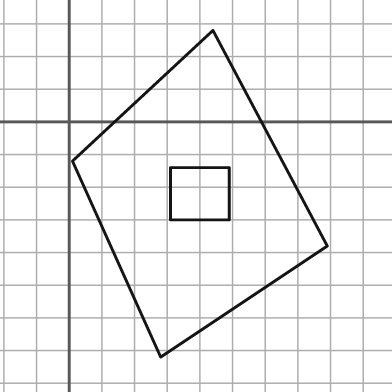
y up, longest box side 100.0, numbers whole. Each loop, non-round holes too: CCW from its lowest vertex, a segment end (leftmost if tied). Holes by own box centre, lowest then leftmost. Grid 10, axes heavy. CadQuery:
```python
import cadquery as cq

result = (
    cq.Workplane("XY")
    .moveTo(28.0, -72.0)
    .lineTo(79.0, -38.0)
    .lineTo(44.0, 28.0)
    .lineTo(1.0, -12.0)
    .close()
    .moveTo(31.0, -30.0)
    .lineTo(49.0, -30.0)
    .lineTo(49.0, -14.0)
    .lineTo(31.0, -14.0)
    .close()
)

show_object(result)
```